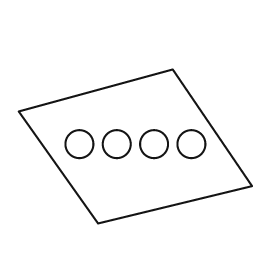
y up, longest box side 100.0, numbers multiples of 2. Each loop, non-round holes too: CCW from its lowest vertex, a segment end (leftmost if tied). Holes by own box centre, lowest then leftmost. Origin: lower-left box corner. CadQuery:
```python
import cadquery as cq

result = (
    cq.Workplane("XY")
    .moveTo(34.0, 0.0)
    .lineTo(100.0, 16.0)
    .lineTo(66.0, 66.0)
    .lineTo(0.0, 48.0)
    .close()
    .moveTo(26.0, 34.0)
    .circle(6.0)
    .moveTo(42.0, 34.0)
    .circle(6.0)
    .moveTo(58.0, 34.0)
    .circle(6.0)
    .moveTo(74.0, 34.0)
    .circle(6.0)
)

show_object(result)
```